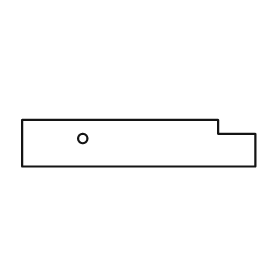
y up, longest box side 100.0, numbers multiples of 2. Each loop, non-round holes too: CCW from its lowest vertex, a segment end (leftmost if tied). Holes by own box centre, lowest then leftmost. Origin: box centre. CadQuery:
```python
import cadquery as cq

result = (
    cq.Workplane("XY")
    .moveTo(-50.0, -10.0)
    .lineTo(50.0, -10.0)
    .lineTo(50.0, 4.0)
    .lineTo(34.0, 4.0)
    .lineTo(34.0, 10.0)
    .lineTo(-50.0, 10.0)
    .close()
    .moveTo(-24.0, 2.0)
    .circle(2.0)
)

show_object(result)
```